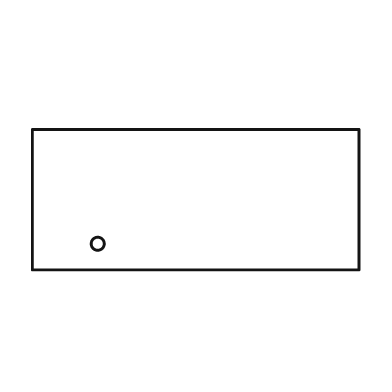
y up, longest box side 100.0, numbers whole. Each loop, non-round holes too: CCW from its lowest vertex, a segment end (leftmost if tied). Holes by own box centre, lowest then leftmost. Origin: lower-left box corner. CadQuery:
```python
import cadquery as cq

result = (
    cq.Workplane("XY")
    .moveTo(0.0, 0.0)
    .lineTo(100.0, 0.0)
    .lineTo(100.0, 43.0)
    .lineTo(0.0, 43.0)
    .close()
    .moveTo(20.0, 8.0)
    .circle(2.0)
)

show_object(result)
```